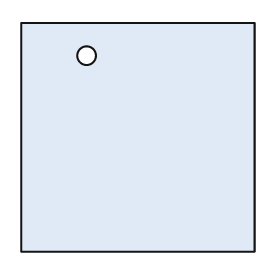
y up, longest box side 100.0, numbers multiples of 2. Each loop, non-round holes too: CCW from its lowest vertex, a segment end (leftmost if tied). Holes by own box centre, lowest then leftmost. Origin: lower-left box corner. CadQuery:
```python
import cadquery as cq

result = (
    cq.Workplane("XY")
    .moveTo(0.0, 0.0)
    .lineTo(100.0, 0.0)
    .lineTo(100.0, 98.0)
    .lineTo(0.0, 98.0)
    .close()
    .moveTo(28.0, 84.0)
    .circle(4.0)
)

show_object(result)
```